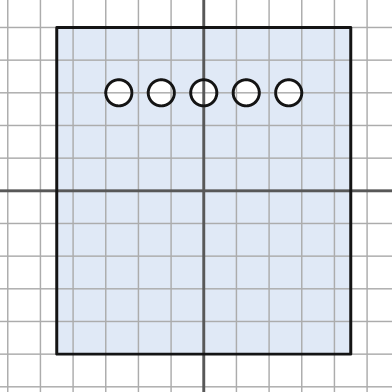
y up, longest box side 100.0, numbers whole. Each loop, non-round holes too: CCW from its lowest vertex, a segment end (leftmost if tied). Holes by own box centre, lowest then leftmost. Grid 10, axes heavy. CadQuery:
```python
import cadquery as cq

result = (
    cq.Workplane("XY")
    .moveTo(-45.0, -50.0)
    .lineTo(45.0, -50.0)
    .lineTo(45.0, 50.0)
    .lineTo(-45.0, 50.0)
    .close()
    .moveTo(-26.0, 30.0)
    .circle(4.0)
    .moveTo(-13.0, 30.0)
    .circle(4.0)
    .moveTo(0.0, 30.0)
    .circle(4.0)
    .moveTo(13.0, 30.0)
    .circle(4.0)
    .moveTo(26.0, 30.0)
    .circle(4.0)
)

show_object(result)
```